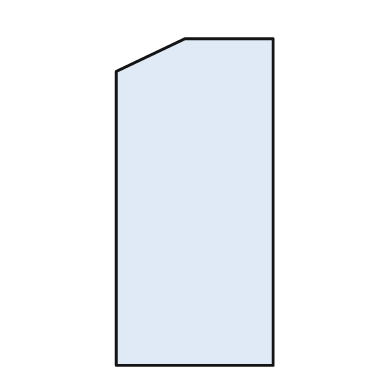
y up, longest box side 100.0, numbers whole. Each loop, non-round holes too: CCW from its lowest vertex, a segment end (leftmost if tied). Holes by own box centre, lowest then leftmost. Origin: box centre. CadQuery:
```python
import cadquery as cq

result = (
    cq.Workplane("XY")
    .moveTo(-24.0, -50.0)
    .lineTo(24.0, -50.0)
    .lineTo(24.0, 50.0)
    .lineTo(-3.0, 50.0)
    .lineTo(-24.0, 40.0)
    .close()
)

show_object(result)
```